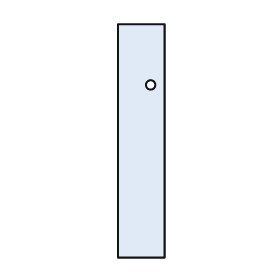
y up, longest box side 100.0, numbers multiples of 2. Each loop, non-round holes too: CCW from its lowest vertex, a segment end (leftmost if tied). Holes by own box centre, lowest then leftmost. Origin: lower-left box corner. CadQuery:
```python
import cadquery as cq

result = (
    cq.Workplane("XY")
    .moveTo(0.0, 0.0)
    .lineTo(20.0, 0.0)
    .lineTo(20.0, 100.0)
    .lineTo(0.0, 100.0)
    .close()
    .moveTo(14.0, 74.0)
    .circle(2.0)
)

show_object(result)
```